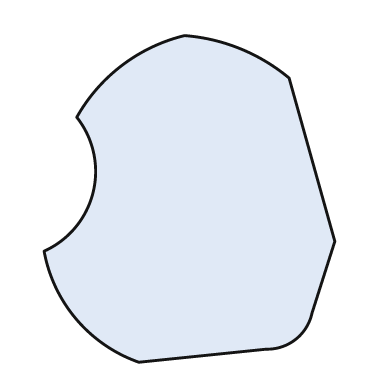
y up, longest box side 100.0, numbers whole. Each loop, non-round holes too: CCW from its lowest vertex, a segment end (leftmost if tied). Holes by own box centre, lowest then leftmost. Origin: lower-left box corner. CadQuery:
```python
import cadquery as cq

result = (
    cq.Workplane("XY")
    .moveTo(29.0, 0.0)
    .lineTo(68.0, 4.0)
    .threePointArc((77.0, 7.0), (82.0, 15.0))
    .lineTo(89.0, 37.0)
    .lineTo(75.0, 87.0)
    .threePointArc((60.0, 96.0), (43.0, 100.0))
    .threePointArc((24.0, 91.0), (10.0, 75.0))
    .threePointArc((15.0, 52.0), (0.0, 34.0))
    .threePointArc((10.0, 13.0), (29.0, 0.0))
    .close()
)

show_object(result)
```